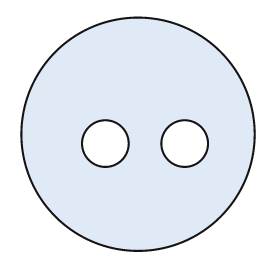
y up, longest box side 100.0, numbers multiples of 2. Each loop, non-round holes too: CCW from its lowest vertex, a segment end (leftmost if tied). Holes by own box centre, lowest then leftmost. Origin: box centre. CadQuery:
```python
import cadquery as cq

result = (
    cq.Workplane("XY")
    .moveTo(0.0, 0.0)
    .circle(50.0)
    .moveTo(-14.0, -4.0)
    .circle(10.0)
    .moveTo(20.0, -4.0)
    .circle(10.0)
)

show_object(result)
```